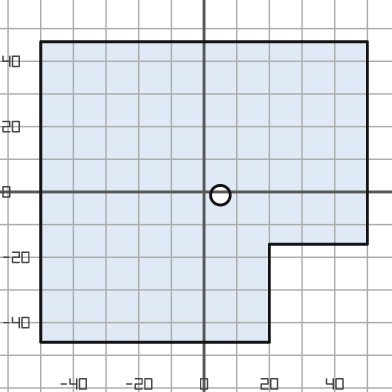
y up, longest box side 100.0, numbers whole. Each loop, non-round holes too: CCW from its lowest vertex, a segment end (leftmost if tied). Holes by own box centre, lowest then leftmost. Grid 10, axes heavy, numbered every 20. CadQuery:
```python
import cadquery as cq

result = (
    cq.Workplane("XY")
    .moveTo(-50.0, -46.0)
    .lineTo(20.0, -46.0)
    .lineTo(20.0, -16.0)
    .lineTo(50.0, -16.0)
    .lineTo(50.0, 46.0)
    .lineTo(-50.0, 46.0)
    .close()
    .moveTo(5.0, -1.0)
    .circle(3.0)
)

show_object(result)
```